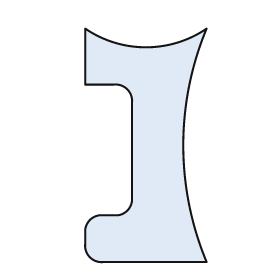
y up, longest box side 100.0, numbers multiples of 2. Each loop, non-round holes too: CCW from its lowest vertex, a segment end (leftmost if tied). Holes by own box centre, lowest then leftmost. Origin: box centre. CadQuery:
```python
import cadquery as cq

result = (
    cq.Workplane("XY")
    .moveTo(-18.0, -50.0)
    .lineTo(26.0, -50.0)
    .threePointArc((16.0, 0.0), (26.0, 50.0))
    .threePointArc((0.0, 42.0), (-26.0, 50.0))
    .lineTo(-26.0, 26.0)
    .lineTo(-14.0, 26.0)
    .threePointArc((-8.0, 24.0), (-6.0, 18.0))
    .lineTo(-6.0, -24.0)
    .threePointArc((-8.0, -28.0), (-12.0, -30.0))
    .lineTo(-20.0, -30.0)
    .threePointArc((-24.0, -32.0), (-26.0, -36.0))
    .lineTo(-26.0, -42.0)
    .threePointArc((-24.0, -48.0), (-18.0, -50.0))
    .close()
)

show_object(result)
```